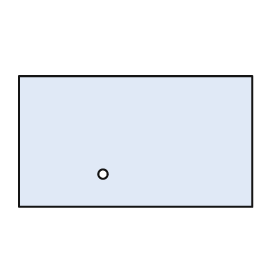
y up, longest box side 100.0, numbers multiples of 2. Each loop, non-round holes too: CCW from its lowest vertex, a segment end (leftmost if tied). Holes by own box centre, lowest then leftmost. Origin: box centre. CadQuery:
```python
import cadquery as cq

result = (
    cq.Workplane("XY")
    .moveTo(-50.0, -28.0)
    .lineTo(50.0, -28.0)
    .lineTo(50.0, 28.0)
    .lineTo(-50.0, 28.0)
    .close()
    .moveTo(-14.0, -14.0)
    .circle(2.0)
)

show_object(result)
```